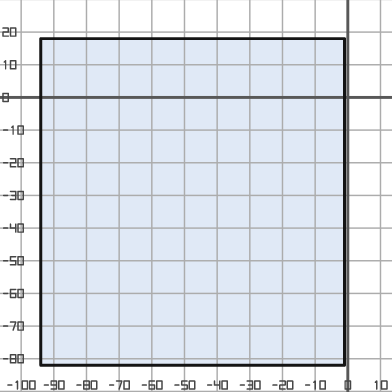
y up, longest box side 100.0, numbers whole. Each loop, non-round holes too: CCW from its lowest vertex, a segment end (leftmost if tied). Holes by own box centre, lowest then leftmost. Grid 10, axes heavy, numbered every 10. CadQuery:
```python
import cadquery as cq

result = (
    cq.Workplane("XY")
    .moveTo(-94.0, -82.0)
    .lineTo(-1.0, -82.0)
    .lineTo(-1.0, 18.0)
    .lineTo(-94.0, 18.0)
    .close()
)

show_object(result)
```